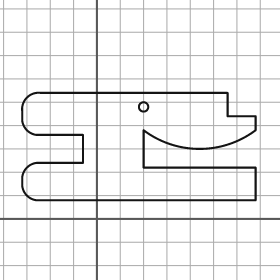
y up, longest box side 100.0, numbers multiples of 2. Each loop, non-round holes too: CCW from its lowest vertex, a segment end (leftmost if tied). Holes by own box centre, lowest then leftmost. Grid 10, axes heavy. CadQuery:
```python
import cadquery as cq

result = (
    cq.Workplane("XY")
    .moveTo(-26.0, 8.0)
    .lineTo(68.0, 8.0)
    .lineTo(68.0, 22.0)
    .lineTo(20.0, 22.0)
    .lineTo(20.0, 38.0)
    .threePointArc((44.0, 30.0), (68.0, 38.0))
    .lineTo(68.0, 44.0)
    .lineTo(56.0, 44.0)
    .lineTo(56.0, 54.0)
    .lineTo(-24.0, 54.0)
    .threePointArc((-30.0, 52.0), (-32.0, 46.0))
    .lineTo(-32.0, 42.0)
    .threePointArc((-30.0, 38.0), (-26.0, 36.0))
    .lineTo(-6.0, 36.0)
    .lineTo(-6.0, 24.0)
    .lineTo(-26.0, 24.0)
    .threePointArc((-30.0, 22.0), (-32.0, 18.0))
    .lineTo(-32.0, 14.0)
    .threePointArc((-30.0, 10.0), (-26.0, 8.0))
    .close()
    .moveTo(20.0, 48.0)
    .circle(2.0)
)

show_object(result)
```